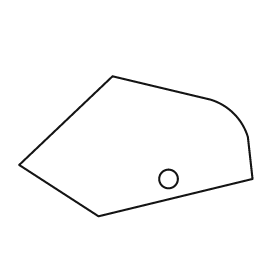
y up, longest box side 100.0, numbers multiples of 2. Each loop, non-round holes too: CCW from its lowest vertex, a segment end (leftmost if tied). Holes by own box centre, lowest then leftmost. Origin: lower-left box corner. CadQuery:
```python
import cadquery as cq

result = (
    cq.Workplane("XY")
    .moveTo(34.0, 0.0)
    .lineTo(100.0, 16.0)
    .lineTo(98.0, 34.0)
    .threePointArc((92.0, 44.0), (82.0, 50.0))
    .lineTo(40.0, 60.0)
    .lineTo(0.0, 22.0)
    .close()
    .moveTo(64.0, 16.0)
    .circle(4.0)
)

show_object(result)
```